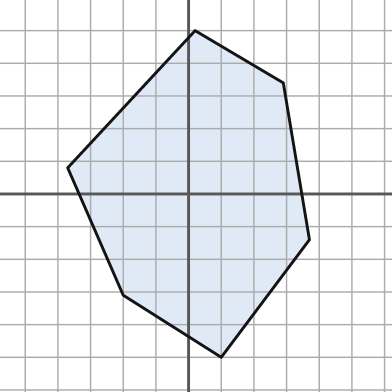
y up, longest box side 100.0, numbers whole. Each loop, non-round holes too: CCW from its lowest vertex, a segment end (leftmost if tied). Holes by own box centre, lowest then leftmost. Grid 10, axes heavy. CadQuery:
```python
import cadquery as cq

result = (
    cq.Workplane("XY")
    .moveTo(10.0, -50.0)
    .lineTo(37.0, -14.0)
    .lineTo(29.0, 34.0)
    .lineTo(2.0, 50.0)
    .lineTo(-37.0, 8.0)
    .lineTo(-20.0, -31.0)
    .close()
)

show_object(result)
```